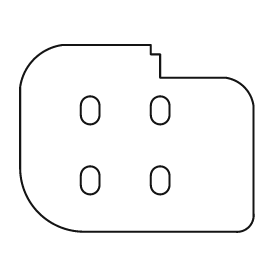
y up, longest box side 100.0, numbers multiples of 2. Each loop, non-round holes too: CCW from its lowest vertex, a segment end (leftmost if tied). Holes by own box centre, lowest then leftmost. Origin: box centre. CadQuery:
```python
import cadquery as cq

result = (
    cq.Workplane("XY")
    .moveTo(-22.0, -40.0)
    .lineTo(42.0, -40.0)
    .threePointArc((48.0, -38.0), (50.0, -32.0))
    .lineTo(50.0, 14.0)
    .threePointArc((46.0, 22.0), (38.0, 26.0))
    .lineTo(10.0, 26.0)
    .lineTo(10.0, 36.0)
    .lineTo(6.0, 36.0)
    .lineTo(6.0, 40.0)
    .lineTo(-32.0, 40.0)
    .threePointArc((-44.0, 34.0), (-50.0, 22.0))
    .lineTo(-50.0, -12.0)
    .threePointArc((-42.0, -32.0), (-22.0, -40.0))
    .close()
    .moveTo(-24.0, -20.0)
    .threePointArc((-20.0, -24.0), (-16.0, -20.0))
    .lineTo(-16.0, -16.0)
    .threePointArc((-20.0, -12.0), (-24.0, -16.0))
    .close()
    .moveTo(6.0, -20.0)
    .threePointArc((10.0, -24.0), (14.0, -20.0))
    .lineTo(14.0, -16.0)
    .threePointArc((10.0, -12.0), (6.0, -16.0))
    .close()
    .moveTo(-24.0, 10.0)
    .threePointArc((-20.0, 6.0), (-16.0, 10.0))
    .lineTo(-16.0, 14.0)
    .threePointArc((-20.0, 18.0), (-24.0, 14.0))
    .close()
    .moveTo(6.0, 10.0)
    .threePointArc((10.0, 6.0), (14.0, 10.0))
    .lineTo(14.0, 14.0)
    .threePointArc((10.0, 18.0), (6.0, 14.0))
    .close()
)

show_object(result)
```